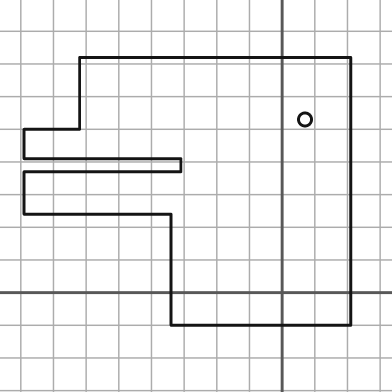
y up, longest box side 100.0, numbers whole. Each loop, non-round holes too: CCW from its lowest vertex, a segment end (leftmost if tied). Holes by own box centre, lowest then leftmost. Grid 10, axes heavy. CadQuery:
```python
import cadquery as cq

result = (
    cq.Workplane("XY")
    .moveTo(-34.0, -10.0)
    .lineTo(21.0, -10.0)
    .lineTo(21.0, 72.0)
    .lineTo(-62.0, 72.0)
    .lineTo(-62.0, 50.0)
    .lineTo(-79.0, 50.0)
    .lineTo(-79.0, 41.0)
    .lineTo(-31.0, 41.0)
    .lineTo(-31.0, 37.0)
    .lineTo(-79.0, 37.0)
    .lineTo(-79.0, 24.0)
    .lineTo(-34.0, 24.0)
    .close()
    .moveTo(7.0, 53.0)
    .circle(2.0)
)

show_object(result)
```